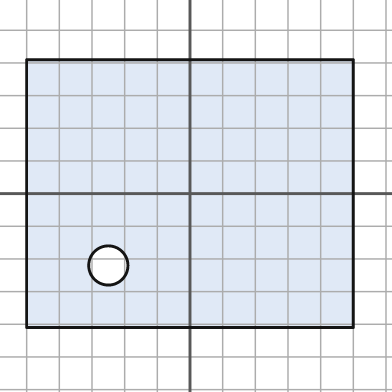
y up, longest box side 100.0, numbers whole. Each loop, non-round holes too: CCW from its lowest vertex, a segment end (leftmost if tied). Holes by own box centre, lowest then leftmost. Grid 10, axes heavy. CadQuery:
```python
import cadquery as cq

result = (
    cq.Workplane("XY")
    .moveTo(-50.0, -41.0)
    .lineTo(50.0, -41.0)
    .lineTo(50.0, 41.0)
    .lineTo(-50.0, 41.0)
    .close()
    .moveTo(-25.0, -22.0)
    .circle(6.0)
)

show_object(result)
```